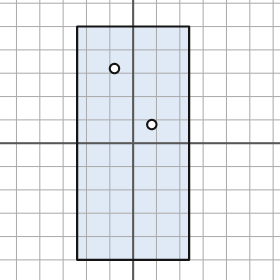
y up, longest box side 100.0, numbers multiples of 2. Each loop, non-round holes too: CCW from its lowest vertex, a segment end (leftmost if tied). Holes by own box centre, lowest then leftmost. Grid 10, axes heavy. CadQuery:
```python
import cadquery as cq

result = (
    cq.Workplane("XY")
    .moveTo(-24.0, -50.0)
    .lineTo(24.0, -50.0)
    .lineTo(24.0, 50.0)
    .lineTo(-24.0, 50.0)
    .close()
    .moveTo(8.0, 8.0)
    .circle(2.0)
    .moveTo(-8.0, 32.0)
    .circle(2.0)
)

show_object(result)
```